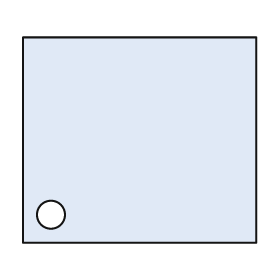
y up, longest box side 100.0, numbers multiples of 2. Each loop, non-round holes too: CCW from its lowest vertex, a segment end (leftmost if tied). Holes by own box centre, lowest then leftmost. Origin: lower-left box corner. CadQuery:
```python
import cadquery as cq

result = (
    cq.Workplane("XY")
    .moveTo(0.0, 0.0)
    .lineTo(100.0, 0.0)
    .lineTo(100.0, 88.0)
    .lineTo(0.0, 88.0)
    .close()
    .moveTo(12.0, 12.0)
    .circle(6.0)
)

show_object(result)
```